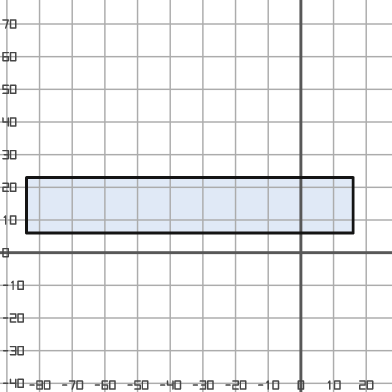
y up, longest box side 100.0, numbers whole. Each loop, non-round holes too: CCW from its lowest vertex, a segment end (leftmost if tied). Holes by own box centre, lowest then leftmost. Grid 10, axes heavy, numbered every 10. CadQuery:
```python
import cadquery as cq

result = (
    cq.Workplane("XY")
    .moveTo(-84.0, 6.0)
    .lineTo(16.0, 6.0)
    .lineTo(16.0, 23.0)
    .lineTo(-84.0, 23.0)
    .close()
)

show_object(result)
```